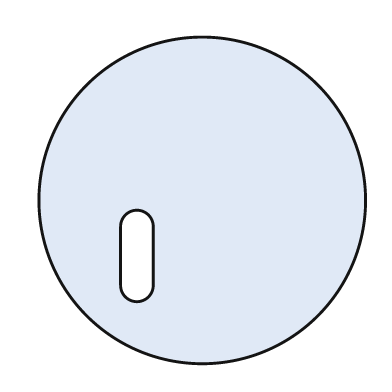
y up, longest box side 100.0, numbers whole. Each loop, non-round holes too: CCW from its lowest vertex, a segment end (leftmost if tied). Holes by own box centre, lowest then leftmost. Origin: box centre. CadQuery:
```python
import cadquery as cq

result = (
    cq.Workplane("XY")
    .moveTo(0.0, 0.0)
    .circle(50.0)
    .moveTo(-25.0, -26.0)
    .threePointArc((-20.0, -31.0), (-15.0, -26.0))
    .lineTo(-15.0, -8.0)
    .threePointArc((-20.0, -3.0), (-25.0, -8.0))
    .close()
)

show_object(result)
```